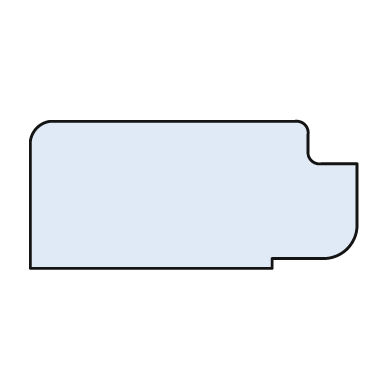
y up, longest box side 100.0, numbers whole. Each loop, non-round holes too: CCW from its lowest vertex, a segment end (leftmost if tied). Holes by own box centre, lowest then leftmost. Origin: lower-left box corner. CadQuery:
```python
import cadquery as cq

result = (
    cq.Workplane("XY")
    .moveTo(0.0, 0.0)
    .lineTo(74.0, 0.0)
    .lineTo(74.0, 3.0)
    .lineTo(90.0, 3.0)
    .threePointArc((97.0, 6.0), (100.0, 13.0))
    .lineTo(100.0, 32.0)
    .lineTo(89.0, 32.0)
    .threePointArc((86.0, 33.0), (85.0, 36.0))
    .lineTo(85.0, 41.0)
    .threePointArc((84.0, 44.0), (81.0, 45.0))
    .lineTo(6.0, 45.0)
    .threePointArc((2.0, 43.0), (0.0, 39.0))
    .close()
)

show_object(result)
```